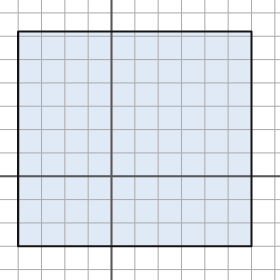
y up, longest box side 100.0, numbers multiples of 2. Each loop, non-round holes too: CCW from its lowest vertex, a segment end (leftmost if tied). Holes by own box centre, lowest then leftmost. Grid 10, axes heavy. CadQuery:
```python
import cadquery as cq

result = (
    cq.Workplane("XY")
    .moveTo(-40.0, -30.0)
    .lineTo(60.0, -30.0)
    .lineTo(60.0, 62.0)
    .lineTo(-40.0, 62.0)
    .close()
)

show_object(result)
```